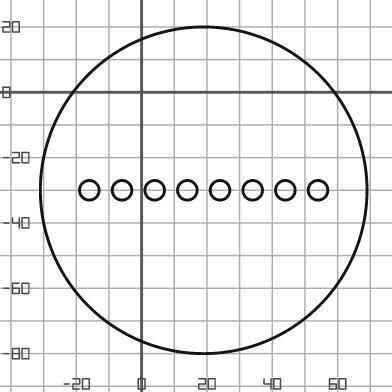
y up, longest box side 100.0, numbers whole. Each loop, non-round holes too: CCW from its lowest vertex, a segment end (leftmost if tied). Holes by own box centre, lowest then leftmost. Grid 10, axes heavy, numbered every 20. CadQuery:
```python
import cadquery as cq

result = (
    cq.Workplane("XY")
    .moveTo(19.0, -30.0)
    .circle(50.0)
    .moveTo(-16.0, -30.0)
    .circle(3.0)
    .moveTo(-6.0, -30.0)
    .circle(3.0)
    .moveTo(4.0, -30.0)
    .circle(3.0)
    .moveTo(14.0, -30.0)
    .circle(3.0)
    .moveTo(24.0, -30.0)
    .circle(3.0)
    .moveTo(34.0, -30.0)
    .circle(3.0)
    .moveTo(44.0, -30.0)
    .circle(3.0)
    .moveTo(54.0, -30.0)
    .circle(3.0)
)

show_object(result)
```